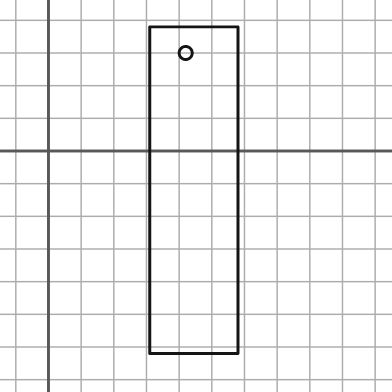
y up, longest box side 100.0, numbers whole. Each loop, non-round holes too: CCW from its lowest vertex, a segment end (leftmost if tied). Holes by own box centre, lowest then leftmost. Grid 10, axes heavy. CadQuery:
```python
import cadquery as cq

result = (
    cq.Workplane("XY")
    .moveTo(31.0, -62.0)
    .lineTo(58.0, -62.0)
    .lineTo(58.0, 38.0)
    .lineTo(31.0, 38.0)
    .close()
    .moveTo(42.0, 30.0)
    .circle(2.0)
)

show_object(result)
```